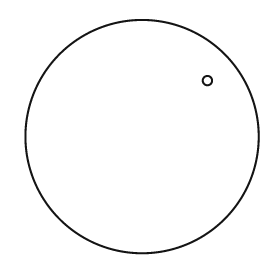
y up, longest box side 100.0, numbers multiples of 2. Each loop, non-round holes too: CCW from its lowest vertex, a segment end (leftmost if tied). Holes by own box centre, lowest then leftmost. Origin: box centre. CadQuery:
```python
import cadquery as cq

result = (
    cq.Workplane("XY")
    .moveTo(0.0, 0.0)
    .circle(50.0)
    .moveTo(28.0, 24.0)
    .circle(2.0)
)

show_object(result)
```